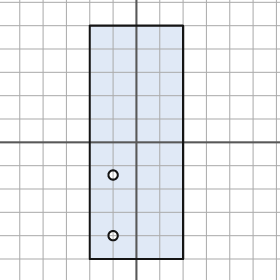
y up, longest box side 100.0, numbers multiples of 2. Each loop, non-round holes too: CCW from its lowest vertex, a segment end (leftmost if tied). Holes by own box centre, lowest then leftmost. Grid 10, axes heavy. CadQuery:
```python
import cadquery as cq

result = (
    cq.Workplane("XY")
    .moveTo(-20.0, -50.0)
    .lineTo(20.0, -50.0)
    .lineTo(20.0, 50.0)
    .lineTo(-20.0, 50.0)
    .close()
    .moveTo(-10.0, -40.0)
    .circle(2.0)
    .moveTo(-10.0, -14.0)
    .circle(2.0)
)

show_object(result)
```